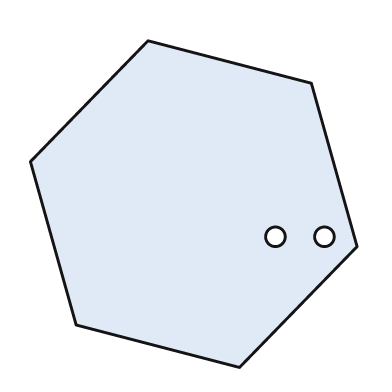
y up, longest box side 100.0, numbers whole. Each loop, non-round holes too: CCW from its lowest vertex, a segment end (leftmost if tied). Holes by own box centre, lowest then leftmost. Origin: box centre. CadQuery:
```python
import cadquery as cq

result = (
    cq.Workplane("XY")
    .moveTo(14.0, -50.0)
    .lineTo(50.0, -13.0)
    .lineTo(36.0, 37.0)
    .lineTo(-14.0, 50.0)
    .lineTo(-50.0, 13.0)
    .lineTo(-36.0, -37.0)
    .close()
    .moveTo(25.0, -10.0)
    .circle(3.0)
    .moveTo(40.0, -10.0)
    .circle(3.0)
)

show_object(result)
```